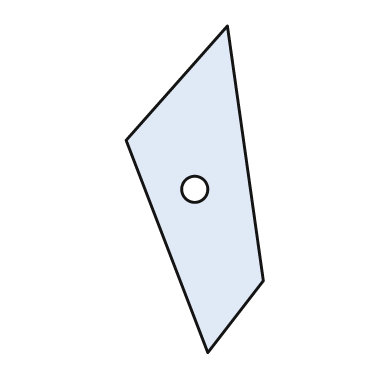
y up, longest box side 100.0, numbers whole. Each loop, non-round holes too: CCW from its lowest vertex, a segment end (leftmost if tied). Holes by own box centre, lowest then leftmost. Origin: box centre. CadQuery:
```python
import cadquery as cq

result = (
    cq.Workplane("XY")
    .moveTo(4.0, -50.0)
    .lineTo(21.0, -28.0)
    .lineTo(10.0, 50.0)
    .lineTo(-21.0, 15.0)
    .close()
    .moveTo(0.0, 0.0)
    .circle(4.0)
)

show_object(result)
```